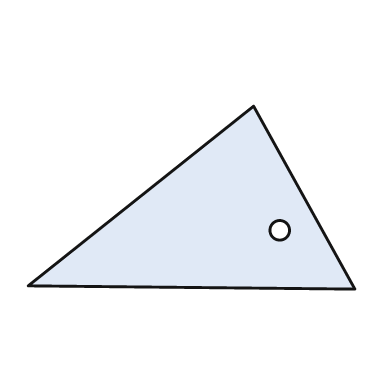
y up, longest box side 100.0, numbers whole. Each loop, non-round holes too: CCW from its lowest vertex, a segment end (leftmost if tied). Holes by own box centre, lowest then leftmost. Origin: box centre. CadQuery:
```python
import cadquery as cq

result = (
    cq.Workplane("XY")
    .moveTo(50.0, -28.0)
    .lineTo(19.0, 28.0)
    .lineTo(-50.0, -27.0)
    .close()
    .moveTo(27.0, -10.0)
    .circle(3.0)
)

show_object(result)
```